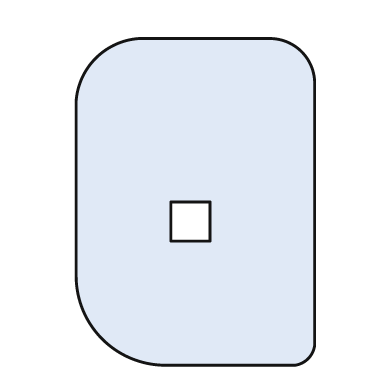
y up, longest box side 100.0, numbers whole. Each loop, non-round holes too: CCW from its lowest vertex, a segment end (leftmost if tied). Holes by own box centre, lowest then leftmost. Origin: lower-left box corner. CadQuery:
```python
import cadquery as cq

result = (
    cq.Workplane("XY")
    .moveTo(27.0, 0.0)
    .lineTo(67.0, 0.0)
    .threePointArc((71.0, 2.0), (73.0, 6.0))
    .lineTo(73.0, 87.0)
    .threePointArc((69.0, 96.0), (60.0, 100.0))
    .lineTo(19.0, 100.0)
    .threePointArc((6.0, 94.0), (0.0, 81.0))
    .lineTo(0.0, 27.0)
    .threePointArc((8.0, 8.0), (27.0, 0.0))
    .close()
    .moveTo(29.0, 38.0)
    .lineTo(41.0, 38.0)
    .lineTo(41.0, 50.0)
    .lineTo(29.0, 50.0)
    .close()
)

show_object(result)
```